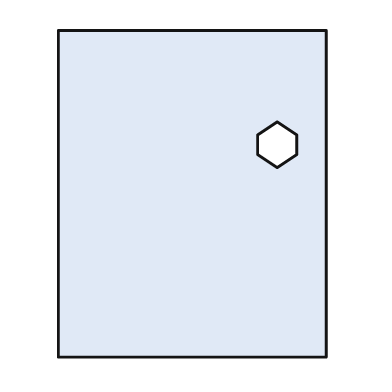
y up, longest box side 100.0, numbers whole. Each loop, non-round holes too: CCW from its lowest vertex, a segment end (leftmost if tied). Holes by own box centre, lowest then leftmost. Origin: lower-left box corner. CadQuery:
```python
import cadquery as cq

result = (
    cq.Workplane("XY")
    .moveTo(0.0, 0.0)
    .lineTo(82.0, 0.0)
    .lineTo(82.0, 100.0)
    .lineTo(0.0, 100.0)
    .close()
    .moveTo(67.0, 58.0)
    .lineTo(73.0, 62.0)
    .lineTo(73.0, 68.0)
    .lineTo(67.0, 72.0)
    .lineTo(61.0, 68.0)
    .lineTo(61.0, 62.0)
    .close()
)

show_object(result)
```